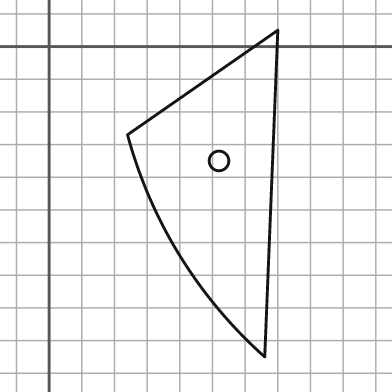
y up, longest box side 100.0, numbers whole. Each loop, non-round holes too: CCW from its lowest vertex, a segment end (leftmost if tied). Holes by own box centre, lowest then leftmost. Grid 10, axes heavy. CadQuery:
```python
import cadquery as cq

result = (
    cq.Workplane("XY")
    .moveTo(66.0, -95.0)
    .lineTo(70.0, 5.0)
    .lineTo(24.0, -27.0)
    .threePointArc((40.0, -64.0), (66.0, -95.0))
    .close()
    .moveTo(52.0, -35.0)
    .circle(3.0)
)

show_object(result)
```